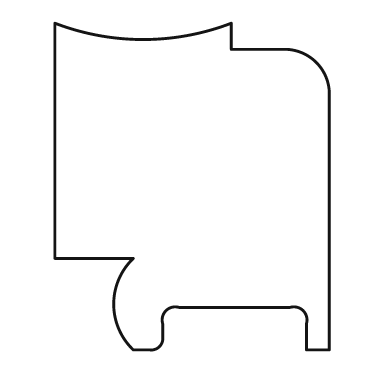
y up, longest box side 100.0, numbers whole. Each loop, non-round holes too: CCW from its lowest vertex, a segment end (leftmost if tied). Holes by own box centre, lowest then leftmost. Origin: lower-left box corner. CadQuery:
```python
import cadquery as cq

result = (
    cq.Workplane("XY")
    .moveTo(24.0, 0.0)
    .lineTo(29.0, 0.0)
    .threePointArc((32.0, 1.0), (33.0, 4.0))
    .lineTo(33.0, 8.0)
    .threePointArc((34.0, 12.0), (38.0, 13.0))
    .lineTo(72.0, 13.0)
    .threePointArc((76.0, 12.0), (77.0, 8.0))
    .lineTo(77.0, 0.0)
    .lineTo(84.0, 0.0)
    .lineTo(84.0, 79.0)
    .threePointArc((80.0, 88.0), (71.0, 92.0))
    .lineTo(54.0, 92.0)
    .lineTo(54.0, 100.0)
    .threePointArc((27.0, 95.0), (0.0, 100.0))
    .lineTo(0.0, 28.0)
    .lineTo(24.0, 28.0)
    .threePointArc((18.0, 14.0), (24.0, 0.0))
    .close()
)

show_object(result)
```